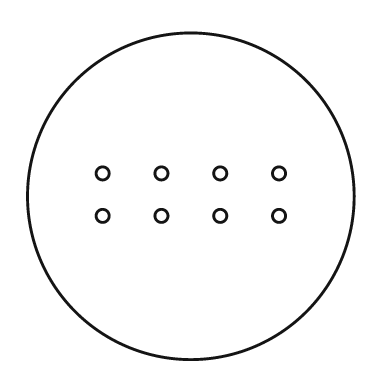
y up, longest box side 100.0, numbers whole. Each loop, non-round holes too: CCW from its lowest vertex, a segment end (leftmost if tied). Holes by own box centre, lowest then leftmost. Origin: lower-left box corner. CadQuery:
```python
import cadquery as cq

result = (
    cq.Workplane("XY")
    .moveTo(50.0, 50.0)
    .circle(50.0)
    .moveTo(23.0, 44.0)
    .circle(2.0)
    .moveTo(41.0, 44.0)
    .circle(2.0)
    .moveTo(59.0, 44.0)
    .circle(2.0)
    .moveTo(77.0, 44.0)
    .circle(2.0)
    .moveTo(23.0, 57.0)
    .circle(2.0)
    .moveTo(41.0, 57.0)
    .circle(2.0)
    .moveTo(59.0, 57.0)
    .circle(2.0)
    .moveTo(77.0, 57.0)
    .circle(2.0)
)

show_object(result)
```